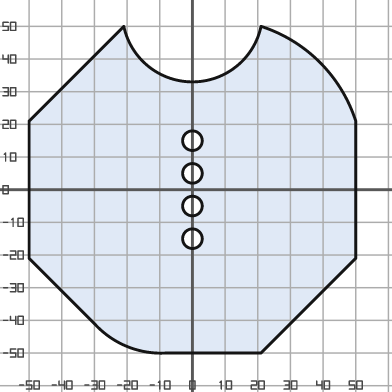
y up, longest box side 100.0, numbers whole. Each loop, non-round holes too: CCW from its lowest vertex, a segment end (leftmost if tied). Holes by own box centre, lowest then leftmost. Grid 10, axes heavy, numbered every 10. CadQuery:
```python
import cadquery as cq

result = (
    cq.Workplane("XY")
    .moveTo(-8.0, -50.0)
    .lineTo(21.0, -50.0)
    .lineTo(50.0, -21.0)
    .lineTo(50.0, 21.0)
    .threePointArc((39.0, 39.0), (21.0, 50.0))
    .threePointArc((0.0, 33.0), (-21.0, 50.0))
    .lineTo(-50.0, 21.0)
    .lineTo(-50.0, -21.0)
    .lineTo(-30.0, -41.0)
    .threePointArc((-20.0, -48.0), (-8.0, -50.0))
    .close()
    .moveTo(0.0, -15.0)
    .circle(3.0)
    .moveTo(0.0, -5.0)
    .circle(3.0)
    .moveTo(0.0, 5.0)
    .circle(3.0)
    .moveTo(0.0, 15.0)
    .circle(3.0)
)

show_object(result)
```